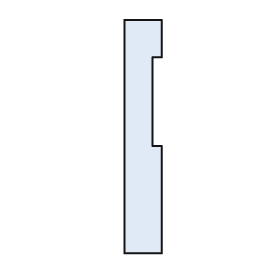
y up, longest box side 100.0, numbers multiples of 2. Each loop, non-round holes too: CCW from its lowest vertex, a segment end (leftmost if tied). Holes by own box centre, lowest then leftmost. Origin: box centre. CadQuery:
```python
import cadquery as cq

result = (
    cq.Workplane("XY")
    .moveTo(-8.0, -50.0)
    .lineTo(8.0, -50.0)
    .lineTo(8.0, -4.0)
    .lineTo(4.0, -4.0)
    .lineTo(4.0, 34.0)
    .lineTo(8.0, 34.0)
    .lineTo(8.0, 50.0)
    .lineTo(-8.0, 50.0)
    .close()
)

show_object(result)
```